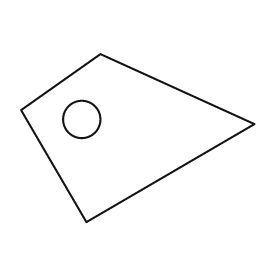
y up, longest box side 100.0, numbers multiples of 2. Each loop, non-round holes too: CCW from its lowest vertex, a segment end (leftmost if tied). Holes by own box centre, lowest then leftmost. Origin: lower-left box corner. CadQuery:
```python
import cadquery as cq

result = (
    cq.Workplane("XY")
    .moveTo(28.0, 0.0)
    .lineTo(100.0, 42.0)
    .lineTo(34.0, 72.0)
    .lineTo(0.0, 48.0)
    .close()
    .moveTo(26.0, 44.0)
    .circle(8.0)
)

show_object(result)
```